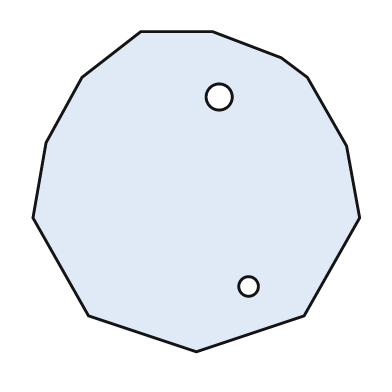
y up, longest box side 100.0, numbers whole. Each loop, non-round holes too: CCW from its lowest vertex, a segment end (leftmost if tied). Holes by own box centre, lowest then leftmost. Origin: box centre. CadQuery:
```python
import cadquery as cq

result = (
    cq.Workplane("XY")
    .moveTo(0.0, -49.0)
    .lineTo(33.0, -38.0)
    .lineTo(50.0, -8.0)
    .lineTo(46.0, 14.0)
    .lineTo(34.0, 35.0)
    .lineTo(26.0, 41.0)
    .lineTo(5.0, 49.0)
    .lineTo(-17.0, 49.0)
    .lineTo(-35.0, 35.0)
    .lineTo(-46.0, 15.0)
    .lineTo(-50.0, -8.0)
    .lineTo(-33.0, -38.0)
    .close()
    .moveTo(16.0, -29.0)
    .circle(3.0)
    .moveTo(7.0, 29.0)
    .circle(4.0)
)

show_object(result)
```